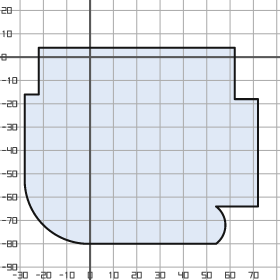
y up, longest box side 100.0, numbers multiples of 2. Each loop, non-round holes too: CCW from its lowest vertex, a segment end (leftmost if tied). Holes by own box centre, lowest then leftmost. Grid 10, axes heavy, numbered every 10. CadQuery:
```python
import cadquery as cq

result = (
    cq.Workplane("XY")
    .moveTo(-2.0, -80.0)
    .lineTo(54.0, -80.0)
    .threePointArc((58.0, -72.0), (54.0, -64.0))
    .lineTo(72.0, -64.0)
    .lineTo(72.0, -18.0)
    .lineTo(62.0, -18.0)
    .lineTo(62.0, 4.0)
    .lineTo(-22.0, 4.0)
    .lineTo(-22.0, -16.0)
    .lineTo(-28.0, -16.0)
    .lineTo(-28.0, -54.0)
    .threePointArc((-20.0, -72.0), (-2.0, -80.0))
    .close()
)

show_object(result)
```